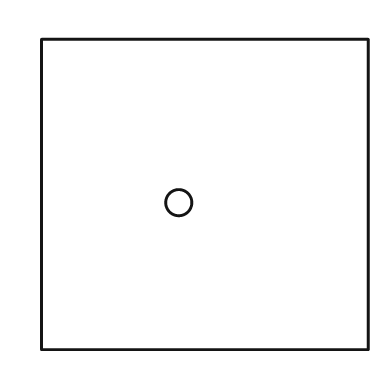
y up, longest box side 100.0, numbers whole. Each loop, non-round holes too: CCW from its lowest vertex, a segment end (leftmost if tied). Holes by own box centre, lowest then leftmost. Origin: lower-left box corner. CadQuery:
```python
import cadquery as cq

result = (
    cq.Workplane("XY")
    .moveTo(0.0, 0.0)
    .lineTo(100.0, 0.0)
    .lineTo(100.0, 95.0)
    .lineTo(0.0, 95.0)
    .close()
    .moveTo(42.0, 45.0)
    .circle(4.0)
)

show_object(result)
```